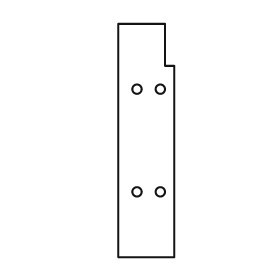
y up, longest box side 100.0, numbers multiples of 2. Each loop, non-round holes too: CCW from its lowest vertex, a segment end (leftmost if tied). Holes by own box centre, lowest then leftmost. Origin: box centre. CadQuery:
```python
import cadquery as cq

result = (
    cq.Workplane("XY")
    .moveTo(-12.0, -50.0)
    .lineTo(12.0, -50.0)
    .lineTo(12.0, 32.0)
    .lineTo(8.0, 32.0)
    .lineTo(8.0, 50.0)
    .lineTo(-12.0, 50.0)
    .close()
    .moveTo(-4.0, -22.0)
    .circle(2.0)
    .moveTo(6.0, -22.0)
    .circle(2.0)
    .moveTo(-4.0, 22.0)
    .circle(2.0)
    .moveTo(6.0, 22.0)
    .circle(2.0)
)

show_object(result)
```